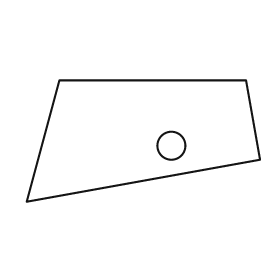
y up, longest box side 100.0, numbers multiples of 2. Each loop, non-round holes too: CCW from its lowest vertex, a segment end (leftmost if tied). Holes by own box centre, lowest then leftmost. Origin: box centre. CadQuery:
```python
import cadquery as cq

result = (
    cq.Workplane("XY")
    .moveTo(-50.0, -26.0)
    .lineTo(50.0, -8.0)
    .lineTo(44.0, 26.0)
    .lineTo(-36.0, 26.0)
    .close()
    .moveTo(12.0, -2.0)
    .circle(6.0)
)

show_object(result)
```